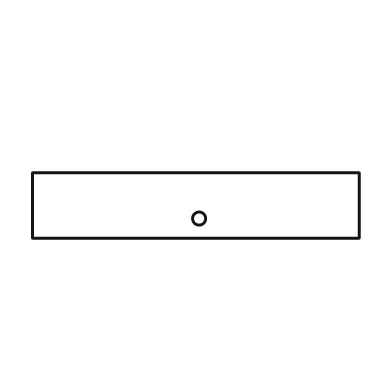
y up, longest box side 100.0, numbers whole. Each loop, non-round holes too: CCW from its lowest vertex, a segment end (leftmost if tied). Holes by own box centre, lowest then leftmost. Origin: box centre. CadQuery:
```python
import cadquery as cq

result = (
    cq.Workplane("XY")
    .moveTo(-50.0, -10.0)
    .lineTo(50.0, -10.0)
    .lineTo(50.0, 10.0)
    .lineTo(-50.0, 10.0)
    .close()
    .moveTo(1.0, -4.0)
    .circle(2.0)
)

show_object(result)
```